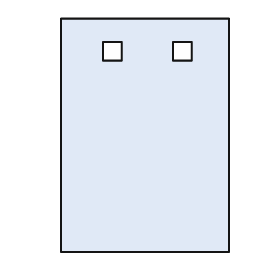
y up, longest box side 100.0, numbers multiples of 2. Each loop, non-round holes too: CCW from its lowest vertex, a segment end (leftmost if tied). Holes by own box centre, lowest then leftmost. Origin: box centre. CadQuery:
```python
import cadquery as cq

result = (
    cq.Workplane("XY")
    .moveTo(-36.0, -50.0)
    .lineTo(36.0, -50.0)
    .lineTo(36.0, 50.0)
    .lineTo(-36.0, 50.0)
    .close()
    .moveTo(-18.0, 32.0)
    .lineTo(-10.0, 32.0)
    .lineTo(-10.0, 40.0)
    .lineTo(-18.0, 40.0)
    .close()
    .moveTo(12.0, 32.0)
    .lineTo(20.0, 32.0)
    .lineTo(20.0, 40.0)
    .lineTo(12.0, 40.0)
    .close()
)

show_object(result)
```